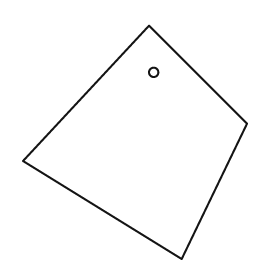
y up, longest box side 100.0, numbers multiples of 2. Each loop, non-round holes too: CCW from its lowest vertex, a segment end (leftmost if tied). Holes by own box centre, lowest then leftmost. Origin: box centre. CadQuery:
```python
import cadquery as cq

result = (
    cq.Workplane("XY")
    .moveTo(20.0, -50.0)
    .lineTo(48.0, 8.0)
    .lineTo(6.0, 50.0)
    .lineTo(-48.0, -8.0)
    .close()
    .moveTo(8.0, 30.0)
    .circle(2.0)
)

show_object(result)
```